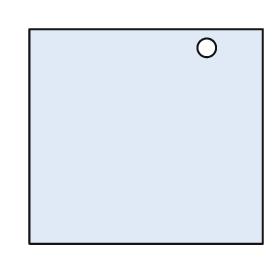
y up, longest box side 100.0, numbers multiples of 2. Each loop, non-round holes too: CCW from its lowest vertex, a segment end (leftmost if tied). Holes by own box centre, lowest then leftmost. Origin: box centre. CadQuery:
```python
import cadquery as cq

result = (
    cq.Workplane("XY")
    .moveTo(-50.0, -46.0)
    .lineTo(50.0, -46.0)
    .lineTo(50.0, 46.0)
    .lineTo(-50.0, 46.0)
    .close()
    .moveTo(26.0, 38.0)
    .circle(4.0)
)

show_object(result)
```